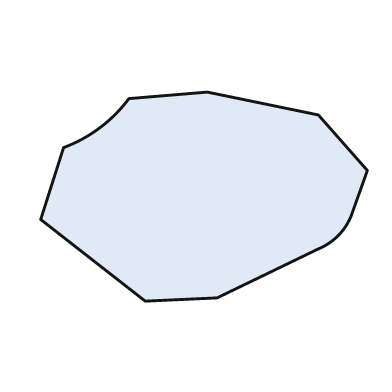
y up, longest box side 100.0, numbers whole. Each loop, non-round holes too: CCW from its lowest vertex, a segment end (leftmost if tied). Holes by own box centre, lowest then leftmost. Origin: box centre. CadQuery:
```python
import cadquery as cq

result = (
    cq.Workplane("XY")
    .moveTo(-18.0, -32.0)
    .lineTo(4.0, -31.0)
    .lineTo(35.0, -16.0)
    .threePointArc((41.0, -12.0), (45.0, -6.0))
    .lineTo(50.0, 8.0)
    .lineTo(35.0, 25.0)
    .lineTo(1.0, 32.0)
    .lineTo(-23.0, 30.0)
    .threePointArc((-32.0, 21.0), (-43.0, 15.0))
    .lineTo(-50.0, -7.0)
    .close()
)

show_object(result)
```